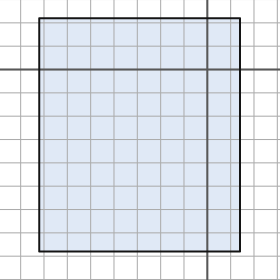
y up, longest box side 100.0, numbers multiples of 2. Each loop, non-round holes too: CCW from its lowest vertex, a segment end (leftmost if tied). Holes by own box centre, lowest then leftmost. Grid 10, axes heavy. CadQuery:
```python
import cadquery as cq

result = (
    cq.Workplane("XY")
    .moveTo(-72.0, -78.0)
    .lineTo(14.0, -78.0)
    .lineTo(14.0, 22.0)
    .lineTo(-72.0, 22.0)
    .close()
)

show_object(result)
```